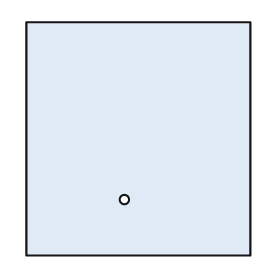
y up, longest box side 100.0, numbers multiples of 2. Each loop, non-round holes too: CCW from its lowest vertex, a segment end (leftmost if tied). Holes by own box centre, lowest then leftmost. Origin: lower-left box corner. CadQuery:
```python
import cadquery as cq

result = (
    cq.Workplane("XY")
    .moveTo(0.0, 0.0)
    .lineTo(96.0, 0.0)
    .lineTo(96.0, 100.0)
    .lineTo(0.0, 100.0)
    .close()
    .moveTo(42.0, 24.0)
    .circle(2.0)
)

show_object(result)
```